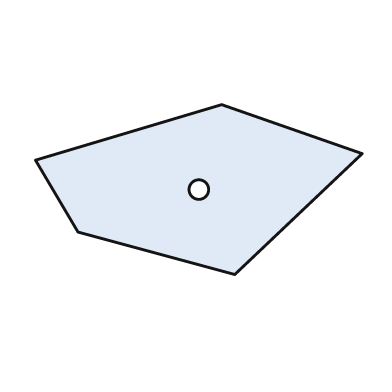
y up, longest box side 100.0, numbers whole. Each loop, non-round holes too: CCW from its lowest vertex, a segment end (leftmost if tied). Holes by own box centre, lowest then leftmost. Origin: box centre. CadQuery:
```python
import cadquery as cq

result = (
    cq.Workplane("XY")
    .moveTo(11.0, -26.0)
    .lineTo(50.0, 11.0)
    .lineTo(7.0, 26.0)
    .lineTo(-50.0, 9.0)
    .lineTo(-37.0, -13.0)
    .close()
    .moveTo(0.0, 0.0)
    .circle(3.0)
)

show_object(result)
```